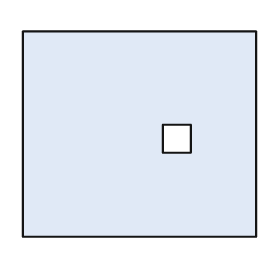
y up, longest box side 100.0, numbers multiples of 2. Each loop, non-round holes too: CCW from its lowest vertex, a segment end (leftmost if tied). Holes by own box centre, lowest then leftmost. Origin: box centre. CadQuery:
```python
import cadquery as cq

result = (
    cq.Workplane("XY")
    .moveTo(-50.0, -44.0)
    .lineTo(50.0, -44.0)
    .lineTo(50.0, 44.0)
    .lineTo(-50.0, 44.0)
    .close()
    .moveTo(10.0, -8.0)
    .lineTo(22.0, -8.0)
    .lineTo(22.0, 4.0)
    .lineTo(10.0, 4.0)
    .close()
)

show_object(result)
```